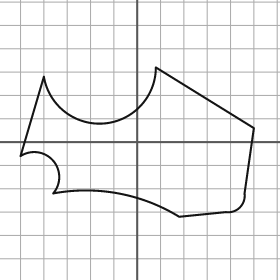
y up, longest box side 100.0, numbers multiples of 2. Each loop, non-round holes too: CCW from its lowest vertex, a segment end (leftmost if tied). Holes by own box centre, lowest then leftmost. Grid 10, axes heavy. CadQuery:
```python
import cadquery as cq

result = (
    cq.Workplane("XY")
    .moveTo(18.0, -32.0)
    .lineTo(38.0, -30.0)
    .threePointArc((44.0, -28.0), (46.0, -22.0))
    .lineTo(50.0, 6.0)
    .lineTo(8.0, 32.0)
    .threePointArc((-14.0, 8.0), (-40.0, 28.0))
    .lineTo(-50.0, -6.0)
    .threePointArc((-36.0, -8.0), (-36.0, -22.0))
    .threePointArc((-8.0, -22.0), (18.0, -32.0))
    .close()
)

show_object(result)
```